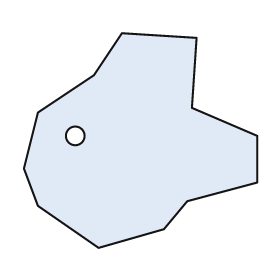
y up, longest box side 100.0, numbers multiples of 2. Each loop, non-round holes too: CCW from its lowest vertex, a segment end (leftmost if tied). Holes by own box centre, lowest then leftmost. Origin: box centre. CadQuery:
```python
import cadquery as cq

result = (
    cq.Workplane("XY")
    .moveTo(-18.0, -46.0)
    .lineTo(10.0, -38.0)
    .lineTo(20.0, -26.0)
    .lineTo(50.0, -18.0)
    .lineTo(50.0, 2.0)
    .lineTo(22.0, 14.0)
    .lineTo(24.0, 44.0)
    .lineTo(-8.0, 46.0)
    .lineTo(-20.0, 28.0)
    .lineTo(-44.0, 12.0)
    .lineTo(-50.0, -12.0)
    .lineTo(-44.0, -28.0)
    .close()
    .moveTo(-28.0, 2.0)
    .circle(4.0)
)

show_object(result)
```